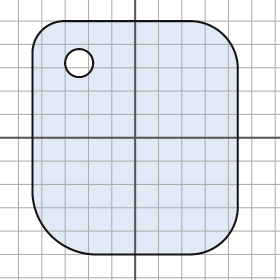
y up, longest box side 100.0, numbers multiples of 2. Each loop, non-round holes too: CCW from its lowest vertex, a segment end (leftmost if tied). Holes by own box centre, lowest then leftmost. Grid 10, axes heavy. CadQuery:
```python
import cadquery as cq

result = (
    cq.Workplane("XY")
    .moveTo(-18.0, -50.0)
    .lineTo(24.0, -50.0)
    .threePointArc((38.0, -44.0), (44.0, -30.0))
    .lineTo(44.0, 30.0)
    .threePointArc((38.0, 44.0), (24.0, 50.0))
    .lineTo(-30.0, 50.0)
    .threePointArc((-40.0, 46.0), (-44.0, 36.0))
    .lineTo(-44.0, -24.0)
    .threePointArc((-36.0, -42.0), (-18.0, -50.0))
    .close()
    .moveTo(-24.0, 32.0)
    .circle(6.0)
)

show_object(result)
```